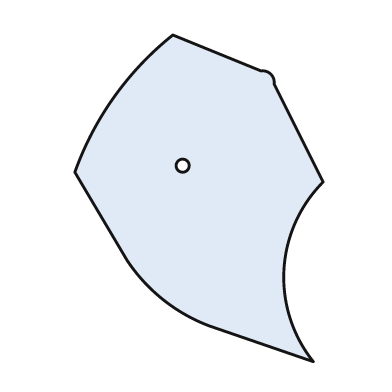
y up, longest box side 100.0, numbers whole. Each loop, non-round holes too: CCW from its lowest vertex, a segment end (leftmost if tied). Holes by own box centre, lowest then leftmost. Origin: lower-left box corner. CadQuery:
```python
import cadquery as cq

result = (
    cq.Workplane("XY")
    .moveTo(73.0, 0.0)
    .threePointArc((64.0, 28.0), (76.0, 55.0))
    .lineTo(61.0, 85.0)
    .threePointArc((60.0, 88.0), (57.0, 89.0))
    .lineTo(30.0, 100.0)
    .threePointArc((12.0, 81.0), (0.0, 58.0))
    .lineTo(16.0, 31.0)
    .threePointArc((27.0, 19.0), (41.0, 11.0))
    .close()
    .moveTo(33.0, 60.0)
    .circle(2.0)
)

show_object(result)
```